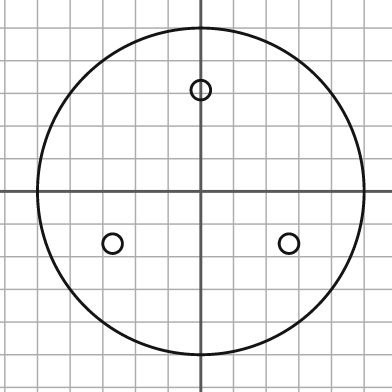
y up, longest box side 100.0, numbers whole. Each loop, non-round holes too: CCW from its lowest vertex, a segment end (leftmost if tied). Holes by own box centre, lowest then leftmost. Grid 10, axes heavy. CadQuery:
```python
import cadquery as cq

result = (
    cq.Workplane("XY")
    .moveTo(0.0, 0.0)
    .circle(50.0)
    .moveTo(-27.0, -16.0)
    .circle(3.0)
    .moveTo(27.0, -16.0)
    .circle(3.0)
    .moveTo(0.0, 31.0)
    .circle(3.0)
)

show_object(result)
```